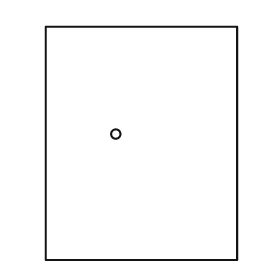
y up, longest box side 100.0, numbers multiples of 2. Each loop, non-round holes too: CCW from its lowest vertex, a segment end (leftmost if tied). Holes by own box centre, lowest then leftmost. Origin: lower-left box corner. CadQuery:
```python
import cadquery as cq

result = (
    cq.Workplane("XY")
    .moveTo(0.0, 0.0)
    .lineTo(82.0, 0.0)
    .lineTo(82.0, 100.0)
    .lineTo(0.0, 100.0)
    .close()
    .moveTo(30.0, 54.0)
    .circle(2.0)
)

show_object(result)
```